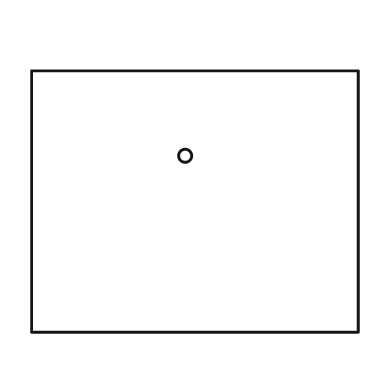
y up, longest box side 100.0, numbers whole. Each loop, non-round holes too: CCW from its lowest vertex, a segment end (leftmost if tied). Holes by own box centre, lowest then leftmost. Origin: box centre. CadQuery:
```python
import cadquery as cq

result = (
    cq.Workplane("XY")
    .moveTo(-50.0, -40.0)
    .lineTo(50.0, -40.0)
    .lineTo(50.0, 40.0)
    .lineTo(-50.0, 40.0)
    .close()
    .moveTo(-3.0, 14.0)
    .circle(2.0)
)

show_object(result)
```